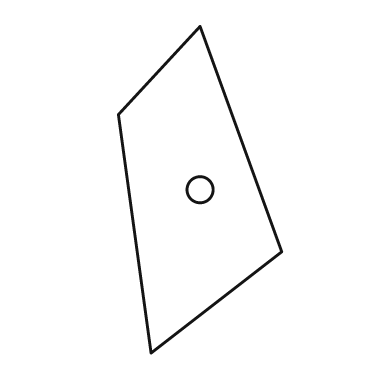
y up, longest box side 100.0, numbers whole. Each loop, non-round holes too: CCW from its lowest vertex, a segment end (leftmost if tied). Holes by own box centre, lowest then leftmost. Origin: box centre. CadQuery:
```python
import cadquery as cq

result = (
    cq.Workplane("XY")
    .moveTo(-15.0, -50.0)
    .lineTo(25.0, -19.0)
    .lineTo(0.0, 50.0)
    .lineTo(-25.0, 23.0)
    .close()
    .moveTo(0.0, 0.0)
    .circle(4.0)
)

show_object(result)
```